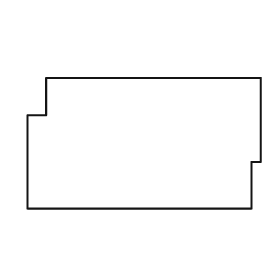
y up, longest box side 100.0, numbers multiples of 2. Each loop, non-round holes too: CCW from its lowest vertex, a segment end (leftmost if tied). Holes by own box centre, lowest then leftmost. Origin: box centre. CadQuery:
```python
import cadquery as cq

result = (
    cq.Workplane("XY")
    .moveTo(-50.0, -28.0)
    .lineTo(46.0, -28.0)
    .lineTo(46.0, -8.0)
    .lineTo(50.0, -8.0)
    .lineTo(50.0, 28.0)
    .lineTo(-42.0, 28.0)
    .lineTo(-42.0, 12.0)
    .lineTo(-50.0, 12.0)
    .close()
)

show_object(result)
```